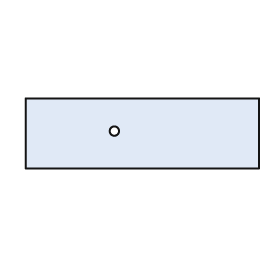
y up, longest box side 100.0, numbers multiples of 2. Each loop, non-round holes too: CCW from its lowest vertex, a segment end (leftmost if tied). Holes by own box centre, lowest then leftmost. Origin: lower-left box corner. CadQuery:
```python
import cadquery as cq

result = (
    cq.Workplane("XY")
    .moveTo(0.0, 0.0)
    .lineTo(100.0, 0.0)
    .lineTo(100.0, 30.0)
    .lineTo(0.0, 30.0)
    .close()
    .moveTo(38.0, 16.0)
    .circle(2.0)
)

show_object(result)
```